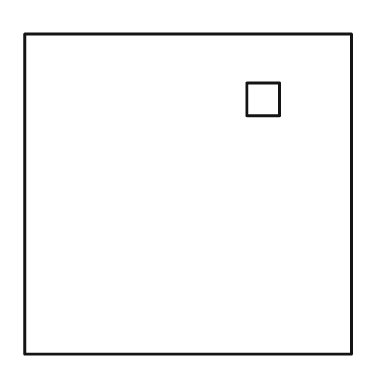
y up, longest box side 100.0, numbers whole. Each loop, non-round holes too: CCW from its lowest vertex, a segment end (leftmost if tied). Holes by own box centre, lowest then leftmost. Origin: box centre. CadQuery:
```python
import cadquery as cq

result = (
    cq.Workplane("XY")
    .moveTo(-50.0, -49.0)
    .lineTo(50.0, -49.0)
    .lineTo(50.0, 49.0)
    .lineTo(-50.0, 49.0)
    .close()
    .moveTo(18.0, 24.0)
    .lineTo(28.0, 24.0)
    .lineTo(28.0, 34.0)
    .lineTo(18.0, 34.0)
    .close()
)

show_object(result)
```